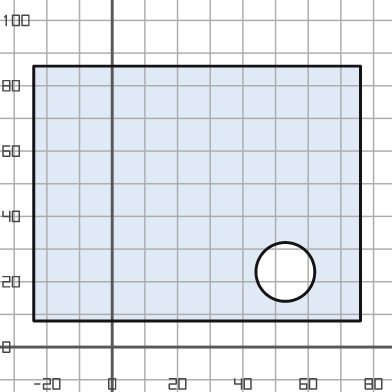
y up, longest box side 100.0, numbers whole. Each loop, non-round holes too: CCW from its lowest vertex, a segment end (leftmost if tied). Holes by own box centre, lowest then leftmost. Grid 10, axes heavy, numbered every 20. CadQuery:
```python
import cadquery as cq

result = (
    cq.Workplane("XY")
    .moveTo(-24.0, 8.0)
    .lineTo(76.0, 8.0)
    .lineTo(76.0, 86.0)
    .lineTo(-24.0, 86.0)
    .close()
    .moveTo(53.0, 23.0)
    .circle(9.0)
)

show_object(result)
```